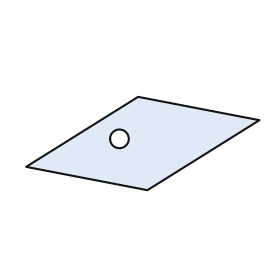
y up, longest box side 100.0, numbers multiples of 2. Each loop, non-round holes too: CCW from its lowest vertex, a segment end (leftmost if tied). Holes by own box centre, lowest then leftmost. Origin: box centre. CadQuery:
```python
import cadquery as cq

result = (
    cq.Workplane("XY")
    .moveTo(2.0, -20.0)
    .lineTo(50.0, 10.0)
    .lineTo(-2.0, 20.0)
    .lineTo(-50.0, -10.0)
    .close()
    .moveTo(-10.0, 2.0)
    .circle(4.0)
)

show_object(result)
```